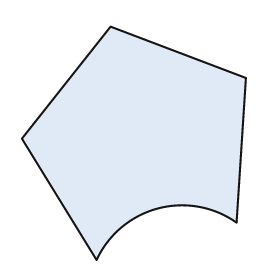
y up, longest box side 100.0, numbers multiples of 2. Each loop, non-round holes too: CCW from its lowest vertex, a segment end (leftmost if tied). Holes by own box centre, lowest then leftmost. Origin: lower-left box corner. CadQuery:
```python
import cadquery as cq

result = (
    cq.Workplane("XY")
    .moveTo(32.0, 0.0)
    .threePointArc((58.0, 22.0), (92.0, 16.0))
    .lineTo(96.0, 78.0)
    .lineTo(38.0, 100.0)
    .lineTo(0.0, 52.0)
    .close()
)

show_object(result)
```